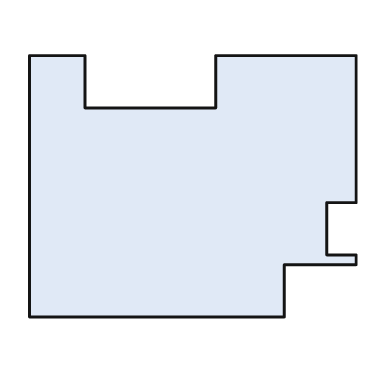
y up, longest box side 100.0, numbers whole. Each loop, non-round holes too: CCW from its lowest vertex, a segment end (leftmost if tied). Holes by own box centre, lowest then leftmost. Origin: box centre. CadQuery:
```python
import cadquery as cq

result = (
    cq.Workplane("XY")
    .moveTo(-50.0, -40.0)
    .lineTo(28.0, -40.0)
    .lineTo(28.0, -24.0)
    .lineTo(50.0, -24.0)
    .lineTo(50.0, -21.0)
    .lineTo(41.0, -21.0)
    .lineTo(41.0, -5.0)
    .lineTo(50.0, -5.0)
    .lineTo(50.0, 40.0)
    .lineTo(7.0, 40.0)
    .lineTo(7.0, 24.0)
    .lineTo(-33.0, 24.0)
    .lineTo(-33.0, 40.0)
    .lineTo(-50.0, 40.0)
    .close()
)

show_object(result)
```